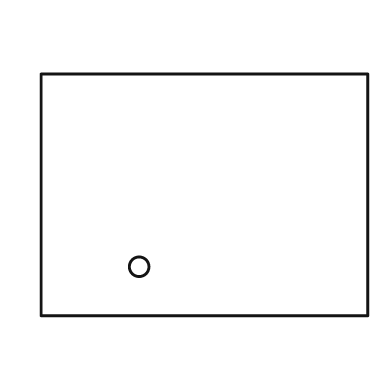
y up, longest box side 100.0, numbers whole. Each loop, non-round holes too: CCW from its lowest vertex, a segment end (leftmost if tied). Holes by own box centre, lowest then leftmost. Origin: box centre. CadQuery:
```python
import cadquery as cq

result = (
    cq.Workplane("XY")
    .moveTo(-50.0, -37.0)
    .lineTo(50.0, -37.0)
    .lineTo(50.0, 37.0)
    .lineTo(-50.0, 37.0)
    .close()
    .moveTo(-20.0, -22.0)
    .circle(3.0)
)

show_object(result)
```